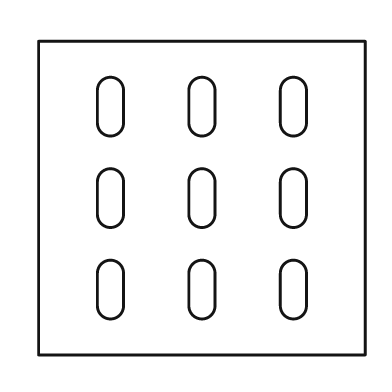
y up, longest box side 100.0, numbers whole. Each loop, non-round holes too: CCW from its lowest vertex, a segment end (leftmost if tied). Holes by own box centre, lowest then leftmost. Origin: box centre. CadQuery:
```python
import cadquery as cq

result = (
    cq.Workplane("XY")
    .moveTo(-50.0, -48.0)
    .lineTo(50.0, -48.0)
    .lineTo(50.0, 48.0)
    .lineTo(-50.0, 48.0)
    .close()
    .moveTo(-32.0, -33.0)
    .threePointArc((-28.0, -37.0), (-24.0, -33.0))
    .lineTo(-24.0, -23.0)
    .threePointArc((-28.0, -19.0), (-32.0, -23.0))
    .close()
    .moveTo(-4.0, -33.0)
    .threePointArc((0.0, -37.0), (4.0, -33.0))
    .lineTo(4.0, -23.0)
    .threePointArc((0.0, -19.0), (-4.0, -23.0))
    .close()
    .moveTo(24.0, -33.0)
    .threePointArc((28.0, -37.0), (32.0, -33.0))
    .lineTo(32.0, -23.0)
    .threePointArc((28.0, -19.0), (24.0, -23.0))
    .close()
    .moveTo(-32.0, -5.0)
    .threePointArc((-28.0, -9.0), (-24.0, -5.0))
    .lineTo(-24.0, 5.0)
    .threePointArc((-28.0, 9.0), (-32.0, 5.0))
    .close()
    .moveTo(-4.0, -5.0)
    .threePointArc((0.0, -9.0), (4.0, -5.0))
    .lineTo(4.0, 5.0)
    .threePointArc((0.0, 9.0), (-4.0, 5.0))
    .close()
    .moveTo(24.0, -5.0)
    .threePointArc((28.0, -9.0), (32.0, -5.0))
    .lineTo(32.0, 5.0)
    .threePointArc((28.0, 9.0), (24.0, 5.0))
    .close()
    .moveTo(-32.0, 23.0)
    .threePointArc((-28.0, 19.0), (-24.0, 23.0))
    .lineTo(-24.0, 33.0)
    .threePointArc((-28.0, 37.0), (-32.0, 33.0))
    .close()
    .moveTo(-4.0, 23.0)
    .threePointArc((0.0, 19.0), (4.0, 23.0))
    .lineTo(4.0, 33.0)
    .threePointArc((0.0, 37.0), (-4.0, 33.0))
    .close()
    .moveTo(24.0, 23.0)
    .threePointArc((28.0, 19.0), (32.0, 23.0))
    .lineTo(32.0, 33.0)
    .threePointArc((28.0, 37.0), (24.0, 33.0))
    .close()
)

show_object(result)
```